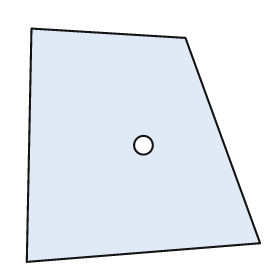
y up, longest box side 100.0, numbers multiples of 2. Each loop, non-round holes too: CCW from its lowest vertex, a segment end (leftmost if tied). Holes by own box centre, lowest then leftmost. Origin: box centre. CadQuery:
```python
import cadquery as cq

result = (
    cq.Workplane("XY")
    .moveTo(-50.0, -50.0)
    .lineTo(50.0, -42.0)
    .lineTo(18.0, 46.0)
    .lineTo(-48.0, 50.0)
    .close()
    .moveTo(0.0, 0.0)
    .circle(4.0)
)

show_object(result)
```